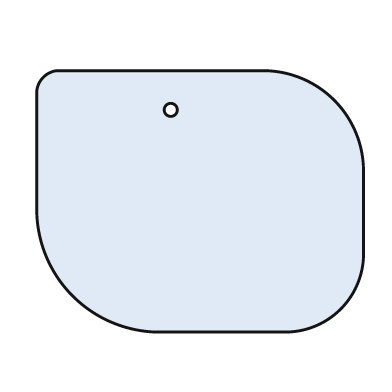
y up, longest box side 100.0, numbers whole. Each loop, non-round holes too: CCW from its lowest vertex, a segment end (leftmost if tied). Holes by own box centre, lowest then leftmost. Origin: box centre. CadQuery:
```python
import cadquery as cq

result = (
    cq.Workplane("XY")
    .moveTo(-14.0, -40.0)
    .lineTo(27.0, -40.0)
    .threePointArc((43.0, -33.0), (50.0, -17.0))
    .lineTo(50.0, 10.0)
    .threePointArc((41.0, 31.0), (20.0, 40.0))
    .lineTo(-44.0, 40.0)
    .threePointArc((-48.0, 38.0), (-50.0, 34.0))
    .lineTo(-50.0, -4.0)
    .threePointArc((-39.0, -29.0), (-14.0, -40.0))
    .close()
    .moveTo(-9.0, 28.0)
    .circle(2.0)
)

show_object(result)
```